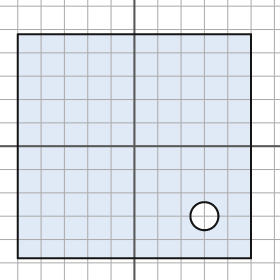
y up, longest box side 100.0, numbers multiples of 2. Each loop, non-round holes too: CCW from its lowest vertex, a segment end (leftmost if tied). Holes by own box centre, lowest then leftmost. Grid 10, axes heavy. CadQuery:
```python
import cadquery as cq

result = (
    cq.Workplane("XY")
    .moveTo(-50.0, -48.0)
    .lineTo(50.0, -48.0)
    .lineTo(50.0, 48.0)
    .lineTo(-50.0, 48.0)
    .close()
    .moveTo(30.0, -30.0)
    .circle(6.0)
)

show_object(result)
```